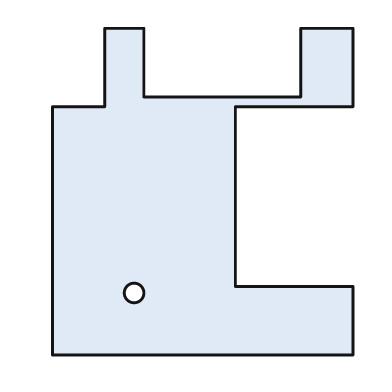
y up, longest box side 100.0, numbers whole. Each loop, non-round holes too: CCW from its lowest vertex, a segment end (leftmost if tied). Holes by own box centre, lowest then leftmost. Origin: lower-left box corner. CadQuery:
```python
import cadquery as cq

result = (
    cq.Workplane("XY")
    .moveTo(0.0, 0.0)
    .lineTo(92.0, 0.0)
    .lineTo(92.0, 21.0)
    .lineTo(56.0, 21.0)
    .lineTo(56.0, 76.0)
    .lineTo(92.0, 76.0)
    .lineTo(92.0, 100.0)
    .lineTo(76.0, 100.0)
    .lineTo(76.0, 79.0)
    .lineTo(28.0, 79.0)
    .lineTo(28.0, 100.0)
    .lineTo(16.0, 100.0)
    .lineTo(16.0, 76.0)
    .lineTo(0.0, 76.0)
    .close()
    .moveTo(25.0, 19.0)
    .circle(3.0)
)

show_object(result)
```